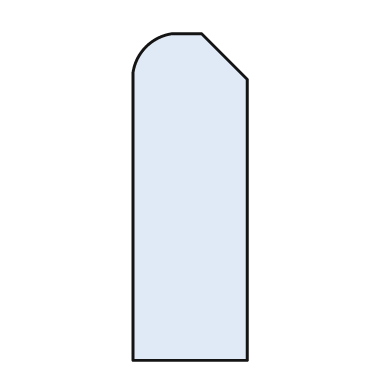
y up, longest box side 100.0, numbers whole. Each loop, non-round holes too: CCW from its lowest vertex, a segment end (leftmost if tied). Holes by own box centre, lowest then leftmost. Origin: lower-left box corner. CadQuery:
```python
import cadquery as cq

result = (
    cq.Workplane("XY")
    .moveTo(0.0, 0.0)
    .lineTo(35.0, 0.0)
    .lineTo(35.0, 86.0)
    .lineTo(21.0, 100.0)
    .lineTo(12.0, 100.0)
    .threePointArc((4.0, 96.0), (0.0, 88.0))
    .close()
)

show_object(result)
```